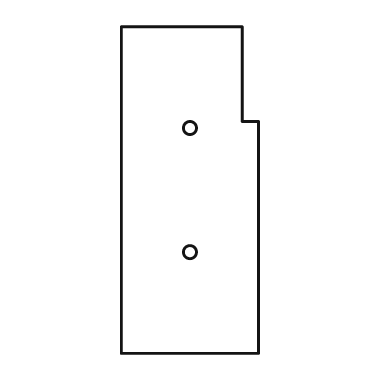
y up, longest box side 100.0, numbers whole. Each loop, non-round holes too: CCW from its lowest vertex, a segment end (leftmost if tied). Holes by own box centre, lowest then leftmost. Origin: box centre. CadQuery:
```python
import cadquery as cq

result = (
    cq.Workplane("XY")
    .moveTo(-21.0, -50.0)
    .lineTo(21.0, -50.0)
    .lineTo(21.0, 21.0)
    .lineTo(16.0, 21.0)
    .lineTo(16.0, 50.0)
    .lineTo(-21.0, 50.0)
    .close()
    .moveTo(0.0, -19.0)
    .circle(2.0)
    .moveTo(0.0, 19.0)
    .circle(2.0)
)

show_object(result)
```